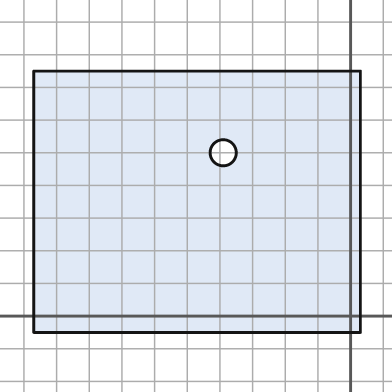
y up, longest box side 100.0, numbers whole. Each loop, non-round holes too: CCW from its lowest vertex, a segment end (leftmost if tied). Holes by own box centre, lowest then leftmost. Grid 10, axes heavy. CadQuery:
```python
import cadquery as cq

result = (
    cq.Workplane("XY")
    .moveTo(-97.0, -5.0)
    .lineTo(3.0, -5.0)
    .lineTo(3.0, 75.0)
    .lineTo(-97.0, 75.0)
    .close()
    .moveTo(-39.0, 50.0)
    .circle(4.0)
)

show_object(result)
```